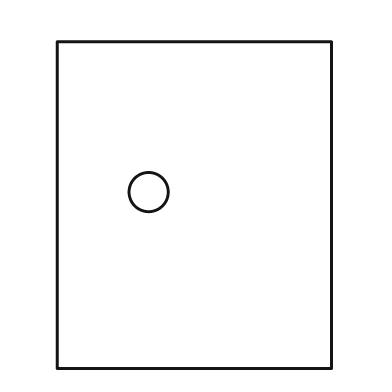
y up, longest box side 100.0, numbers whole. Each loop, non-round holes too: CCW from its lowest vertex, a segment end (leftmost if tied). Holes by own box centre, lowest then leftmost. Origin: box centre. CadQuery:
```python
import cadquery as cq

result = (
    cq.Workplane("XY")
    .moveTo(-42.0, -50.0)
    .lineTo(42.0, -50.0)
    .lineTo(42.0, 50.0)
    .lineTo(-42.0, 50.0)
    .close()
    .moveTo(-14.0, 4.0)
    .circle(6.0)
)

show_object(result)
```